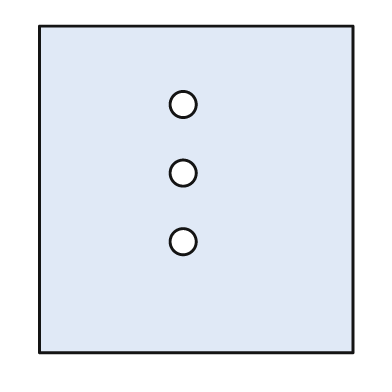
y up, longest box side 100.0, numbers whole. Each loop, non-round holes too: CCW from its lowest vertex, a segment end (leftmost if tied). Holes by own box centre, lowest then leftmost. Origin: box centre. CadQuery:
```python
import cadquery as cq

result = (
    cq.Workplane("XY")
    .moveTo(-48.0, -50.0)
    .lineTo(48.0, -50.0)
    .lineTo(48.0, 50.0)
    .lineTo(-48.0, 50.0)
    .close()
    .moveTo(-4.0, -16.0)
    .circle(4.0)
    .moveTo(-4.0, 5.0)
    .circle(4.0)
    .moveTo(-4.0, 26.0)
    .circle(4.0)
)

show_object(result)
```